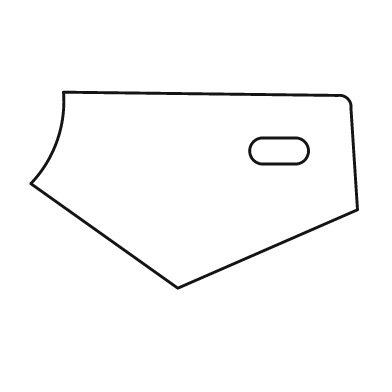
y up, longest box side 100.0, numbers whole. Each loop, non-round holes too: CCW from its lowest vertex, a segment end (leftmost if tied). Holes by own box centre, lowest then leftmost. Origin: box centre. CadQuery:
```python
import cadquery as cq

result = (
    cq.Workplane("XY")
    .moveTo(-5.0, -30.0)
    .lineTo(50.0, -6.0)
    .lineTo(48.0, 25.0)
    .threePointArc((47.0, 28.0), (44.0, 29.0))
    .lineTo(-40.0, 30.0)
    .threePointArc((-42.0, 15.0), (-50.0, 2.0))
    .close()
    .moveTo(21.0, 8.0)
    .lineTo(31.0, 8.0)
    .threePointArc((35.0, 12.0), (31.0, 16.0))
    .lineTo(21.0, 16.0)
    .threePointArc((17.0, 12.0), (21.0, 8.0))
    .close()
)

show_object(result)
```